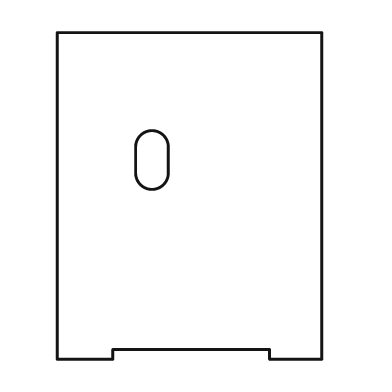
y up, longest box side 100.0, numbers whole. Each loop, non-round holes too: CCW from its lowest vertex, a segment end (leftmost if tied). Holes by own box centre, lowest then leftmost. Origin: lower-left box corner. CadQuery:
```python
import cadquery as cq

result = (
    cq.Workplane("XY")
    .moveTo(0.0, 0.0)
    .lineTo(17.0, 0.0)
    .lineTo(17.0, 3.0)
    .lineTo(65.0, 3.0)
    .lineTo(65.0, 0.0)
    .lineTo(81.0, 0.0)
    .lineTo(81.0, 100.0)
    .lineTo(0.0, 100.0)
    .close()
    .moveTo(24.0, 57.0)
    .threePointArc((29.0, 52.0), (34.0, 57.0))
    .lineTo(34.0, 65.0)
    .threePointArc((29.0, 70.0), (24.0, 65.0))
    .close()
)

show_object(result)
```